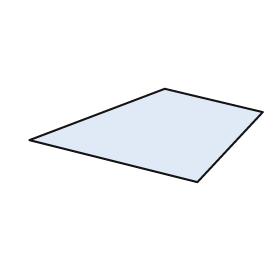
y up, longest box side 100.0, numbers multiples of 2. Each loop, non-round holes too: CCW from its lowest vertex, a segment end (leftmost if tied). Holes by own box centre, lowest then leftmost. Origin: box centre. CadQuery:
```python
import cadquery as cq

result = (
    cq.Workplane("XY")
    .moveTo(22.0, -20.0)
    .lineTo(50.0, 10.0)
    .lineTo(8.0, 20.0)
    .lineTo(-50.0, -2.0)
    .close()
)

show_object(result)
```